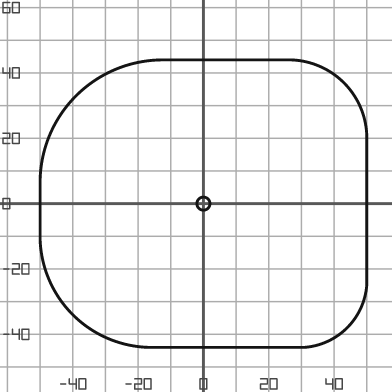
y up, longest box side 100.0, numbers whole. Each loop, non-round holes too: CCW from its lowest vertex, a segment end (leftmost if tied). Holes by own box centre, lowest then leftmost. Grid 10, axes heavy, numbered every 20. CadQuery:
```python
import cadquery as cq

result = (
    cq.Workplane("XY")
    .moveTo(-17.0, -44.0)
    .lineTo(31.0, -44.0)
    .threePointArc((44.0, -38.0), (50.0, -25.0))
    .lineTo(50.0, 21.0)
    .threePointArc((43.0, 37.0), (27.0, 44.0))
    .lineTo(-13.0, 44.0)
    .threePointArc((-39.0, 33.0), (-50.0, 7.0))
    .lineTo(-50.0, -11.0)
    .threePointArc((-40.0, -34.0), (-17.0, -44.0))
    .close()
    .moveTo(0.0, 0.0)
    .circle(2.0)
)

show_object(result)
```